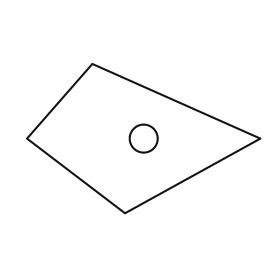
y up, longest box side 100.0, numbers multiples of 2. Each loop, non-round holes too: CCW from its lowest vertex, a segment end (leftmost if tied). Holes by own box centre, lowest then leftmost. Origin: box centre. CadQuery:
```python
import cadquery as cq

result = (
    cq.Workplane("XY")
    .moveTo(-8.0, -32.0)
    .lineTo(50.0, 0.0)
    .lineTo(-22.0, 32.0)
    .lineTo(-50.0, 0.0)
    .close()
    .moveTo(0.0, 0.0)
    .circle(6.0)
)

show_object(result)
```